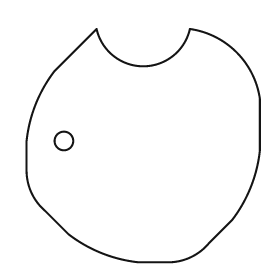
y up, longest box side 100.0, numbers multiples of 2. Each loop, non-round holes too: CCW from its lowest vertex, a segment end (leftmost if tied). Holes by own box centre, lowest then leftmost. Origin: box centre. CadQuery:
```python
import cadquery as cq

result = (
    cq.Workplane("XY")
    .moveTo(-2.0, -50.0)
    .lineTo(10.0, -50.0)
    .threePointArc((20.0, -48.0), (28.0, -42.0))
    .lineTo(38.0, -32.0)
    .threePointArc((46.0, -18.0), (50.0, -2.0))
    .lineTo(50.0, 20.0)
    .threePointArc((40.0, 40.0), (20.0, 50.0))
    .threePointArc((0.0, 34.0), (-20.0, 50.0))
    .lineTo(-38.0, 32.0)
    .threePointArc((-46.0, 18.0), (-50.0, 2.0))
    .lineTo(-50.0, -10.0)
    .threePointArc((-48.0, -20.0), (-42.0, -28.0))
    .lineTo(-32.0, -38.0)
    .threePointArc((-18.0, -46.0), (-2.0, -50.0))
    .close()
    .moveTo(-34.0, 2.0)
    .circle(4.0)
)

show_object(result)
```